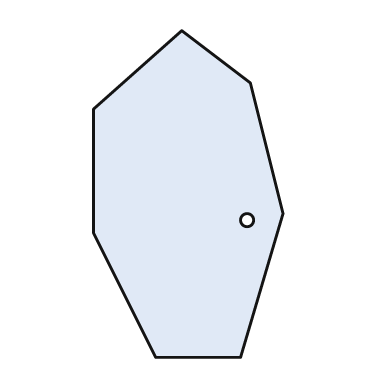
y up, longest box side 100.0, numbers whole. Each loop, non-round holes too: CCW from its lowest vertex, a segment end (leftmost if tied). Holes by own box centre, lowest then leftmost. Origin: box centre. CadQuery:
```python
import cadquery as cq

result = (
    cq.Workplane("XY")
    .moveTo(-10.0, -50.0)
    .lineTo(16.0, -50.0)
    .lineTo(29.0, -6.0)
    .lineTo(19.0, 34.0)
    .lineTo(-2.0, 50.0)
    .lineTo(-29.0, 26.0)
    .lineTo(-29.0, -12.0)
    .close()
    .moveTo(18.0, -8.0)
    .circle(2.0)
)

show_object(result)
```